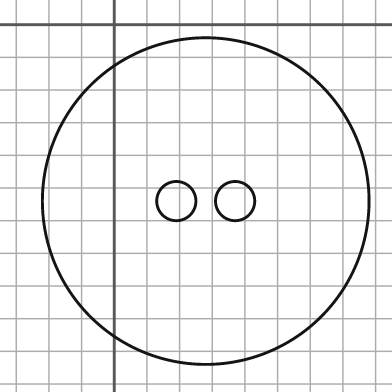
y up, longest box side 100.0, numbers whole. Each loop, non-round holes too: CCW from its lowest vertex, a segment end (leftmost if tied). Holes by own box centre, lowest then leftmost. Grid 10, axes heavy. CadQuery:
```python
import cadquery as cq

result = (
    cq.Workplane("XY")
    .moveTo(28.0, -54.0)
    .circle(50.0)
    .moveTo(19.0, -54.0)
    .circle(6.0)
    .moveTo(37.0, -54.0)
    .circle(6.0)
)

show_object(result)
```